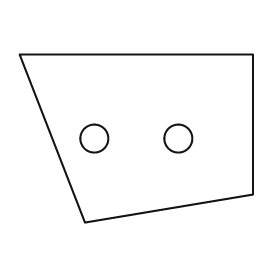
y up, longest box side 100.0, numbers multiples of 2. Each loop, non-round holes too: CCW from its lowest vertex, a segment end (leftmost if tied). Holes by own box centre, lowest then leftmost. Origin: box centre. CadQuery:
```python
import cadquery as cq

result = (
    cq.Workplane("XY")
    .moveTo(-22.0, -36.0)
    .lineTo(50.0, -24.0)
    .lineTo(50.0, 36.0)
    .lineTo(-50.0, 36.0)
    .close()
    .moveTo(-18.0, 0.0)
    .circle(6.0)
    .moveTo(18.0, 0.0)
    .circle(6.0)
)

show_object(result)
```